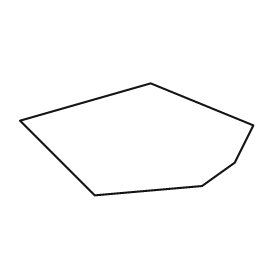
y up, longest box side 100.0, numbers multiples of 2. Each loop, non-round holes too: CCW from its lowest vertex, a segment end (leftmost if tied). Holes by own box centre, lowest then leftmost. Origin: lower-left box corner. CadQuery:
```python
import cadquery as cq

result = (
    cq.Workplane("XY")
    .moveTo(32.0, 0.0)
    .lineTo(78.0, 4.0)
    .lineTo(92.0, 14.0)
    .lineTo(100.0, 30.0)
    .lineTo(56.0, 48.0)
    .lineTo(0.0, 32.0)
    .close()
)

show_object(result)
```